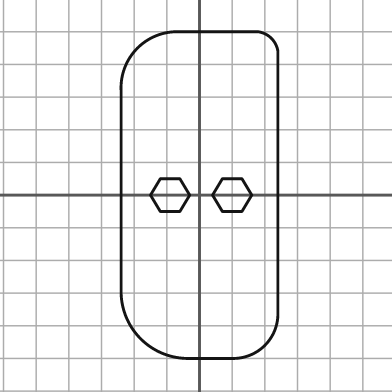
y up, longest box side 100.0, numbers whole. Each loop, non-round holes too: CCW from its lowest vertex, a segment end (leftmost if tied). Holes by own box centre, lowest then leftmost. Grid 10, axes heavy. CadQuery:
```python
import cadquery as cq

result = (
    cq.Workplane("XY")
    .moveTo(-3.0, -50.0)
    .lineTo(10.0, -50.0)
    .threePointArc((20.0, -46.0), (24.0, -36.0))
    .lineTo(24.0, 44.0)
    .threePointArc((22.0, 48.0), (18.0, 50.0))
    .lineTo(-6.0, 50.0)
    .threePointArc((-19.0, 45.0), (-24.0, 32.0))
    .lineTo(-24.0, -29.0)
    .threePointArc((-18.0, -44.0), (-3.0, -50.0))
    .close()
    .moveTo(-12.0, -5.0)
    .lineTo(-6.0, -5.0)
    .lineTo(-3.0, 0.0)
    .lineTo(-6.0, 5.0)
    .lineTo(-12.0, 5.0)
    .lineTo(-15.0, 0.0)
    .close()
    .moveTo(7.0, -5.0)
    .lineTo(13.0, -5.0)
    .lineTo(16.0, 0.0)
    .lineTo(13.0, 5.0)
    .lineTo(7.0, 5.0)
    .lineTo(4.0, 0.0)
    .close()
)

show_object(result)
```